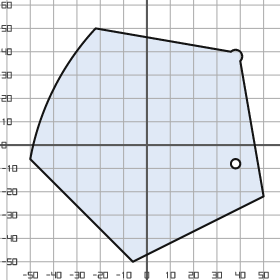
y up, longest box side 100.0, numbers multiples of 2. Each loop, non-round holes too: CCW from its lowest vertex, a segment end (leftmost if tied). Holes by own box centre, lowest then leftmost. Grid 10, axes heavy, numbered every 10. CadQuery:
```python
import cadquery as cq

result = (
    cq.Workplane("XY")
    .moveTo(-6.0, -50.0)
    .lineTo(50.0, -22.0)
    .lineTo(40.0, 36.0)
    .threePointArc((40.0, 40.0), (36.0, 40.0))
    .lineTo(-22.0, 50.0)
    .threePointArc((-40.0, 24.0), (-50.0, -6.0))
    .close()
    .moveTo(38.0, -8.0)
    .circle(2.0)
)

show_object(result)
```